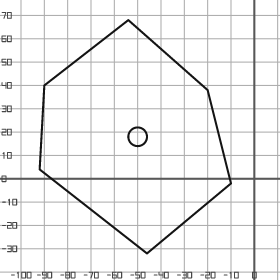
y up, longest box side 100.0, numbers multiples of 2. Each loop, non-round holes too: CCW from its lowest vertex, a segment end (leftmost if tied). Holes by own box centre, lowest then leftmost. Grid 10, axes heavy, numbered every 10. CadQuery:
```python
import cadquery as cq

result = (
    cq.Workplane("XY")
    .moveTo(-46.0, -32.0)
    .lineTo(-10.0, -2.0)
    .lineTo(-20.0, 38.0)
    .lineTo(-54.0, 68.0)
    .lineTo(-90.0, 40.0)
    .lineTo(-92.0, 4.0)
    .close()
    .moveTo(-50.0, 18.0)
    .circle(4.0)
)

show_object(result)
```